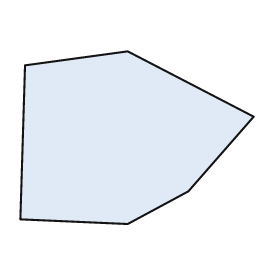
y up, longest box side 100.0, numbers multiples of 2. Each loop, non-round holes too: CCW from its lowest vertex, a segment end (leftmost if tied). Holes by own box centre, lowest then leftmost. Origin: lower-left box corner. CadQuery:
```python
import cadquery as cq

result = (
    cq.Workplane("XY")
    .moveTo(46.0, 0.0)
    .lineTo(72.0, 14.0)
    .lineTo(100.0, 46.0)
    .lineTo(46.0, 74.0)
    .lineTo(2.0, 68.0)
    .lineTo(0.0, 2.0)
    .close()
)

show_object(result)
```